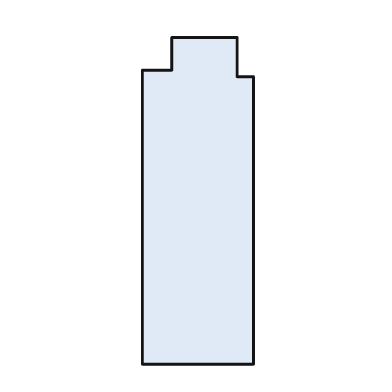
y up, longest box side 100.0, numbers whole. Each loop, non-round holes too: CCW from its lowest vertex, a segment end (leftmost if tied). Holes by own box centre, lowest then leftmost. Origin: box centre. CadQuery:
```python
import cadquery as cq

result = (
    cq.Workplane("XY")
    .moveTo(-17.0, -50.0)
    .lineTo(17.0, -50.0)
    .lineTo(17.0, 38.0)
    .lineTo(12.0, 38.0)
    .lineTo(12.0, 50.0)
    .lineTo(-8.0, 50.0)
    .lineTo(-8.0, 40.0)
    .lineTo(-17.0, 40.0)
    .close()
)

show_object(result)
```